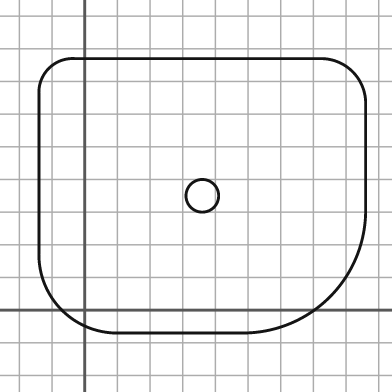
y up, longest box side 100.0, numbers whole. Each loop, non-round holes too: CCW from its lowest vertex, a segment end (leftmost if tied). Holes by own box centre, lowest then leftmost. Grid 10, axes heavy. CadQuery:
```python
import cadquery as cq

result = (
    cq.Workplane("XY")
    .moveTo(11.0, -7.0)
    .lineTo(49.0, -7.0)
    .threePointArc((75.0, 4.0), (86.0, 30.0))
    .lineTo(86.0, 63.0)
    .threePointArc((82.0, 73.0), (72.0, 77.0))
    .lineTo(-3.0, 77.0)
    .threePointArc((-11.0, 74.0), (-14.0, 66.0))
    .lineTo(-14.0, 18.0)
    .threePointArc((-7.0, 0.0), (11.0, -7.0))
    .close()
    .moveTo(36.0, 35.0)
    .circle(5.0)
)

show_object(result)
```